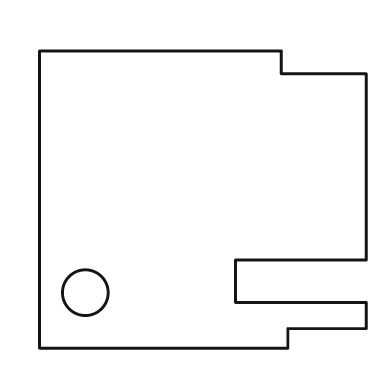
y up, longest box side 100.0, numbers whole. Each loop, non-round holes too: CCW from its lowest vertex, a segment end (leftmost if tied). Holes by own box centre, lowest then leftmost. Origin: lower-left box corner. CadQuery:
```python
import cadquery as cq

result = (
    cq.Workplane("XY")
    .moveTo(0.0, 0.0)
    .lineTo(76.0, 0.0)
    .lineTo(76.0, 6.0)
    .lineTo(100.0, 6.0)
    .lineTo(100.0, 14.0)
    .lineTo(60.0, 14.0)
    .lineTo(60.0, 27.0)
    .lineTo(100.0, 27.0)
    .lineTo(100.0, 84.0)
    .lineTo(74.0, 84.0)
    .lineTo(74.0, 91.0)
    .lineTo(0.0, 91.0)
    .close()
    .moveTo(14.0, 17.0)
    .circle(7.0)
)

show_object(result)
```